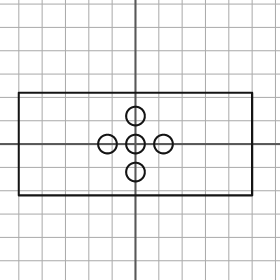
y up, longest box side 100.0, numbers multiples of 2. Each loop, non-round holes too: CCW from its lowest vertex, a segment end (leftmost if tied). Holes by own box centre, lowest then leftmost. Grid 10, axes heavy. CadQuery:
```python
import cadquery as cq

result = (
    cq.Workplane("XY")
    .moveTo(-50.0, -22.0)
    .lineTo(50.0, -22.0)
    .lineTo(50.0, 22.0)
    .lineTo(-50.0, 22.0)
    .close()
    .moveTo(0.0, -12.0)
    .circle(4.0)
    .moveTo(-12.0, 0.0)
    .circle(4.0)
    .moveTo(0.0, 0.0)
    .circle(4.0)
    .moveTo(12.0, 0.0)
    .circle(4.0)
    .moveTo(0.0, 12.0)
    .circle(4.0)
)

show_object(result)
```